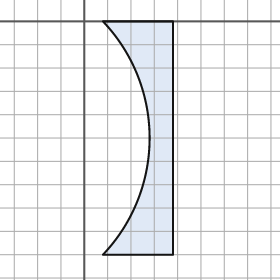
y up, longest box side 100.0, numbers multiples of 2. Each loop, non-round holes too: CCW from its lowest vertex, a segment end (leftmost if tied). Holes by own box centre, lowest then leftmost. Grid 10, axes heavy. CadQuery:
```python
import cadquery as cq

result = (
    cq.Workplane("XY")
    .moveTo(8.0, -100.0)
    .lineTo(38.0, -100.0)
    .lineTo(38.0, 0.0)
    .lineTo(8.0, 0.0)
    .threePointArc((28.0, -50.0), (8.0, -100.0))
    .close()
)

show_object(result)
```